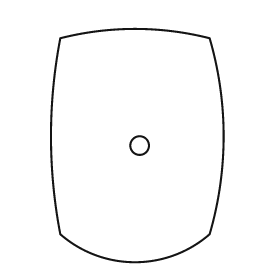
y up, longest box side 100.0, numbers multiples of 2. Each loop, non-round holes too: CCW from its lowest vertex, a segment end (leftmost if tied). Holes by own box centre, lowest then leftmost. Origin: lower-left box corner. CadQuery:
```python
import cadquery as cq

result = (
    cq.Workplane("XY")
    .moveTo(4.0, 12.0)
    .threePointArc((36.0, 0.0), (68.0, 12.0))
    .threePointArc((74.0, 54.0), (68.0, 96.0))
    .threePointArc((36.0, 100.0), (4.0, 96.0))
    .threePointArc((0.0, 54.0), (4.0, 12.0))
    .close()
    .moveTo(38.0, 50.0)
    .circle(4.0)
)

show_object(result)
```